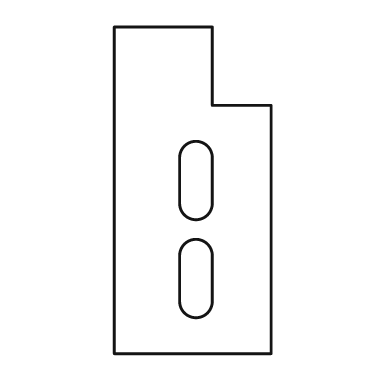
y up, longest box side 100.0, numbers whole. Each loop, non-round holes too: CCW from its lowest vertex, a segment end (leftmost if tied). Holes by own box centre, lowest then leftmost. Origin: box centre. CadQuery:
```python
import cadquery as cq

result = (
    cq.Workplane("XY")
    .moveTo(-24.0, -50.0)
    .lineTo(24.0, -50.0)
    .lineTo(24.0, 26.0)
    .lineTo(6.0, 26.0)
    .lineTo(6.0, 50.0)
    .lineTo(-24.0, 50.0)
    .close()
    .moveTo(-4.0, -34.0)
    .threePointArc((1.0, -39.0), (6.0, -34.0))
    .lineTo(6.0, -20.0)
    .threePointArc((1.0, -15.0), (-4.0, -20.0))
    .close()
    .moveTo(-4.0, -4.0)
    .threePointArc((1.0, -9.0), (6.0, -4.0))
    .lineTo(6.0, 10.0)
    .threePointArc((1.0, 15.0), (-4.0, 10.0))
    .close()
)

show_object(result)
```